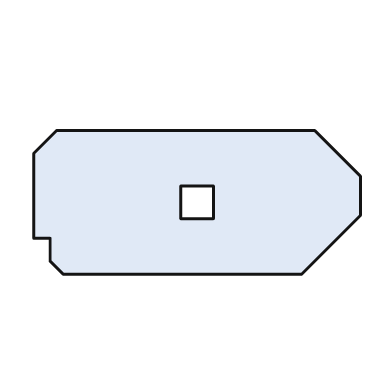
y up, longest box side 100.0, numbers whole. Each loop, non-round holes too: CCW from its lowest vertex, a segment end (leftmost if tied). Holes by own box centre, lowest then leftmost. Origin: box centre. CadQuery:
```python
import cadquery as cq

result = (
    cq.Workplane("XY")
    .moveTo(-41.0, -22.0)
    .lineTo(32.0, -22.0)
    .lineTo(50.0, -4.0)
    .lineTo(50.0, 8.0)
    .lineTo(36.0, 22.0)
    .lineTo(-43.0, 22.0)
    .lineTo(-50.0, 15.0)
    .lineTo(-50.0, -11.0)
    .lineTo(-45.0, -11.0)
    .lineTo(-45.0, -18.0)
    .close()
    .moveTo(-5.0, -5.0)
    .lineTo(5.0, -5.0)
    .lineTo(5.0, 5.0)
    .lineTo(-5.0, 5.0)
    .close()
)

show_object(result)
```